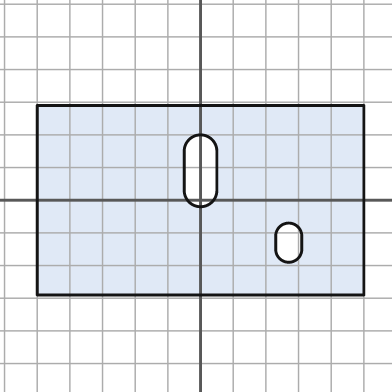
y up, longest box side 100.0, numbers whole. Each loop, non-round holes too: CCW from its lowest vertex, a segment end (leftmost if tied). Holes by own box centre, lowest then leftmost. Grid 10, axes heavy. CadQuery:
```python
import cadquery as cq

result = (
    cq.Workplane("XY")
    .moveTo(-50.0, -29.0)
    .lineTo(50.0, -29.0)
    .lineTo(50.0, 29.0)
    .lineTo(-50.0, 29.0)
    .close()
    .moveTo(23.0, -15.0)
    .threePointArc((27.0, -19.0), (31.0, -15.0))
    .lineTo(31.0, -11.0)
    .threePointArc((27.0, -7.0), (23.0, -11.0))
    .close()
    .moveTo(-5.0, 3.0)
    .threePointArc((0.0, -2.0), (5.0, 3.0))
    .lineTo(5.0, 15.0)
    .threePointArc((0.0, 20.0), (-5.0, 15.0))
    .close()
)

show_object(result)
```